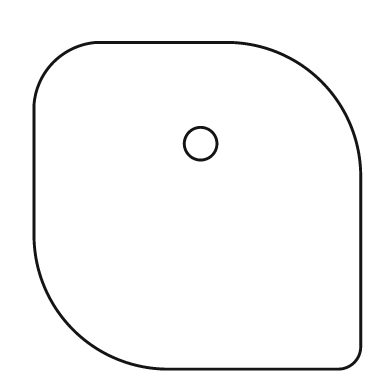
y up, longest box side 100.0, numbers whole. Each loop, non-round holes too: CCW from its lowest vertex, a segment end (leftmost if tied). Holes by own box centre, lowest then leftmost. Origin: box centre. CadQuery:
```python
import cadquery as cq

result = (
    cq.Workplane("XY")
    .moveTo(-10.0, -50.0)
    .lineTo(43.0, -50.0)
    .threePointArc((48.0, -48.0), (50.0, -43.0))
    .lineTo(50.0, 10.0)
    .threePointArc((38.0, 38.0), (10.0, 50.0))
    .lineTo(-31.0, 50.0)
    .threePointArc((-44.0, 44.0), (-50.0, 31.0))
    .lineTo(-50.0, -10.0)
    .threePointArc((-38.0, -38.0), (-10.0, -50.0))
    .close()
    .moveTo(1.0, 19.0)
    .circle(5.0)
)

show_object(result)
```